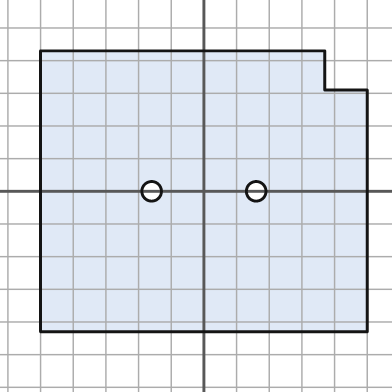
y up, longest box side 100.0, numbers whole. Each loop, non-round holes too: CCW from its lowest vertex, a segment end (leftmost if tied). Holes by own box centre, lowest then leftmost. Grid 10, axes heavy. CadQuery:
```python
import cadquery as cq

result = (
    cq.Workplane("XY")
    .moveTo(-50.0, -43.0)
    .lineTo(50.0, -43.0)
    .lineTo(50.0, 31.0)
    .lineTo(37.0, 31.0)
    .lineTo(37.0, 43.0)
    .lineTo(-50.0, 43.0)
    .close()
    .moveTo(-16.0, 0.0)
    .circle(3.0)
    .moveTo(16.0, 0.0)
    .circle(3.0)
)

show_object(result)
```